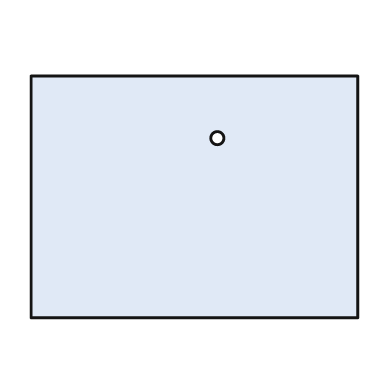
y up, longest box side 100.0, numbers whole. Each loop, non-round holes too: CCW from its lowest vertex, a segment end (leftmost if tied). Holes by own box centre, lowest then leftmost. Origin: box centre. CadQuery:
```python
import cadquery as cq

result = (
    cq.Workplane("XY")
    .moveTo(-50.0, -37.0)
    .lineTo(50.0, -37.0)
    .lineTo(50.0, 37.0)
    .lineTo(-50.0, 37.0)
    .close()
    .moveTo(7.0, 18.0)
    .circle(2.0)
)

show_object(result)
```